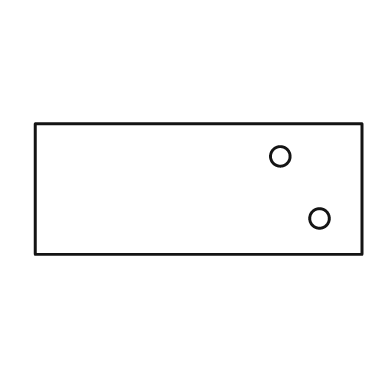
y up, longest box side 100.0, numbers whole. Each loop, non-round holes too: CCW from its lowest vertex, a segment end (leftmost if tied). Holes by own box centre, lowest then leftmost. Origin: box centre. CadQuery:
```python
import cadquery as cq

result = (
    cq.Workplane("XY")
    .moveTo(-50.0, -20.0)
    .lineTo(50.0, -20.0)
    .lineTo(50.0, 20.0)
    .lineTo(-50.0, 20.0)
    .close()
    .moveTo(37.0, -9.0)
    .circle(3.0)
    .moveTo(25.0, 10.0)
    .circle(3.0)
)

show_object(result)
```